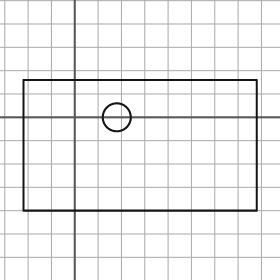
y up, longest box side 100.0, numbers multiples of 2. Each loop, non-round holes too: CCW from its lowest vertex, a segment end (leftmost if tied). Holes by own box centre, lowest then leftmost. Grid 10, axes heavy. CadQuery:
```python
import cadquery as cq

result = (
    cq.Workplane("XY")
    .moveTo(-22.0, -40.0)
    .lineTo(78.0, -40.0)
    .lineTo(78.0, 16.0)
    .lineTo(-22.0, 16.0)
    .close()
    .moveTo(18.0, 0.0)
    .circle(6.0)
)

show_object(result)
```